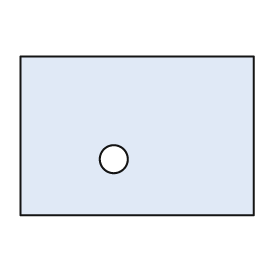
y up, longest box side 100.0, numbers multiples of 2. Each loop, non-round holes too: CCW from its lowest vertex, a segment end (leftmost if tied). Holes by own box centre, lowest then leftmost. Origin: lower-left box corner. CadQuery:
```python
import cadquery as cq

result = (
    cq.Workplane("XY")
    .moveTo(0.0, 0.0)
    .lineTo(100.0, 0.0)
    .lineTo(100.0, 68.0)
    .lineTo(0.0, 68.0)
    .close()
    .moveTo(40.0, 24.0)
    .circle(6.0)
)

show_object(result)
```